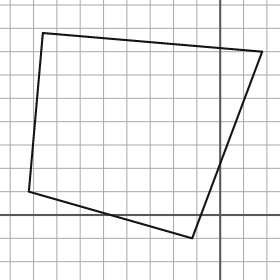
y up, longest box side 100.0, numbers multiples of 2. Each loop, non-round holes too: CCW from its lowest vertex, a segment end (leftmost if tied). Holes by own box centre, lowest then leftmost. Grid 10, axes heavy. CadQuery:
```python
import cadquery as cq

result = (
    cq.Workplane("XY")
    .moveTo(-12.0, -10.0)
    .lineTo(18.0, 70.0)
    .lineTo(-76.0, 78.0)
    .lineTo(-82.0, 10.0)
    .close()
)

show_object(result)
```